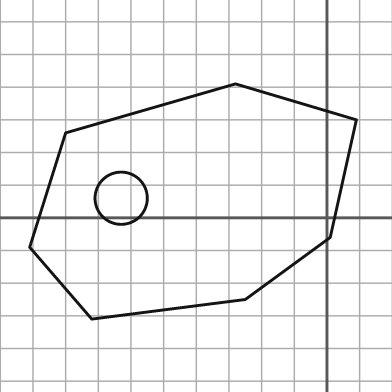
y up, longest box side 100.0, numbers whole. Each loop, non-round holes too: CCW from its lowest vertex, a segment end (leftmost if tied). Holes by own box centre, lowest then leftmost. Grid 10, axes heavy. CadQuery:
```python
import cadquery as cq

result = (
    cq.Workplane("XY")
    .moveTo(-72.0, -31.0)
    .lineTo(-25.0, -25.0)
    .lineTo(1.0, -6.0)
    .lineTo(9.0, 30.0)
    .lineTo(-28.0, 41.0)
    .lineTo(-80.0, 26.0)
    .lineTo(-91.0, -9.0)
    .close()
    .moveTo(-63.0, 6.0)
    .circle(8.0)
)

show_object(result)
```